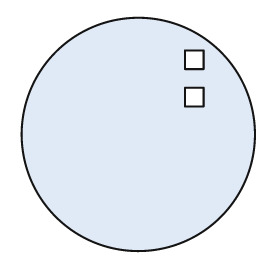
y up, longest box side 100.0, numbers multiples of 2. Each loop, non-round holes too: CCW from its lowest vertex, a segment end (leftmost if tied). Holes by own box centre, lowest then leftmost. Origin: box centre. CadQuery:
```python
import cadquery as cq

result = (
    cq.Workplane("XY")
    .moveTo(0.0, 0.0)
    .circle(50.0)
    .moveTo(20.0, 12.0)
    .lineTo(28.0, 12.0)
    .lineTo(28.0, 20.0)
    .lineTo(20.0, 20.0)
    .close()
    .moveTo(20.0, 28.0)
    .lineTo(28.0, 28.0)
    .lineTo(28.0, 36.0)
    .lineTo(20.0, 36.0)
    .close()
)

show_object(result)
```